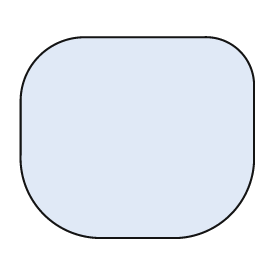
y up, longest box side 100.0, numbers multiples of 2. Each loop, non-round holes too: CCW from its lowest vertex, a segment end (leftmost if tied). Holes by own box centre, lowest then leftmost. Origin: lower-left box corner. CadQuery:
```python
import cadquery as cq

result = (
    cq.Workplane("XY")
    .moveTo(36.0, 0.0)
    .lineTo(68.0, 0.0)
    .threePointArc((90.0, 10.0), (100.0, 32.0))
    .lineTo(100.0, 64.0)
    .threePointArc((94.0, 80.0), (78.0, 86.0))
    .lineTo(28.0, 86.0)
    .threePointArc((8.0, 78.0), (0.0, 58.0))
    .lineTo(0.0, 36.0)
    .threePointArc((10.0, 10.0), (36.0, 0.0))
    .close()
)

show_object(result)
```